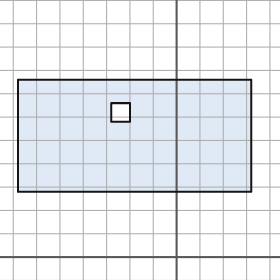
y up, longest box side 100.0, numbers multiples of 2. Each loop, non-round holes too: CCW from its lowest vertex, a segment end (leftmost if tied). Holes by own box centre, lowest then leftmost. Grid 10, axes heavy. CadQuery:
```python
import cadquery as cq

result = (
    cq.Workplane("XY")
    .moveTo(-68.0, 28.0)
    .lineTo(32.0, 28.0)
    .lineTo(32.0, 76.0)
    .lineTo(-68.0, 76.0)
    .close()
    .moveTo(-28.0, 58.0)
    .lineTo(-20.0, 58.0)
    .lineTo(-20.0, 66.0)
    .lineTo(-28.0, 66.0)
    .close()
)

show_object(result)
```